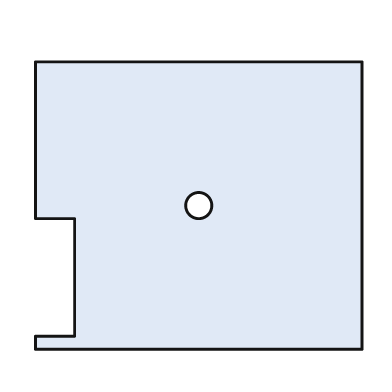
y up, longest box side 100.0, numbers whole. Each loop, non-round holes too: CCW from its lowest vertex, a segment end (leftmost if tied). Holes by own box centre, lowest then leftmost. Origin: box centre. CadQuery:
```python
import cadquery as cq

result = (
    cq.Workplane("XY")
    .moveTo(-50.0, -44.0)
    .lineTo(50.0, -44.0)
    .lineTo(50.0, 44.0)
    .lineTo(-50.0, 44.0)
    .lineTo(-50.0, -4.0)
    .lineTo(-38.0, -4.0)
    .lineTo(-38.0, -40.0)
    .lineTo(-50.0, -40.0)
    .close()
    .moveTo(0.0, 0.0)
    .circle(4.0)
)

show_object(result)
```